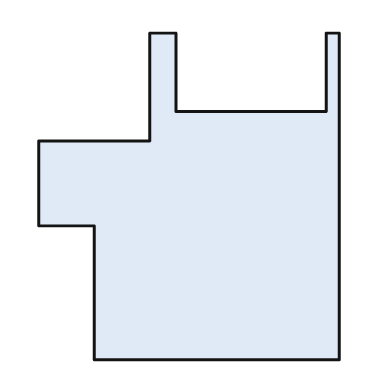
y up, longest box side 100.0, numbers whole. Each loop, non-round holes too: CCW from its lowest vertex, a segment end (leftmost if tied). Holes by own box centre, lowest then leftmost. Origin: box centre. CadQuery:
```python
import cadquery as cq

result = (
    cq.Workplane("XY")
    .moveTo(-29.0, -50.0)
    .lineTo(46.0, -50.0)
    .lineTo(46.0, 50.0)
    .lineTo(42.0, 50.0)
    .lineTo(42.0, 26.0)
    .lineTo(-4.0, 26.0)
    .lineTo(-4.0, 50.0)
    .lineTo(-12.0, 50.0)
    .lineTo(-12.0, 17.0)
    .lineTo(-46.0, 17.0)
    .lineTo(-46.0, -9.0)
    .lineTo(-29.0, -9.0)
    .close()
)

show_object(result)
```